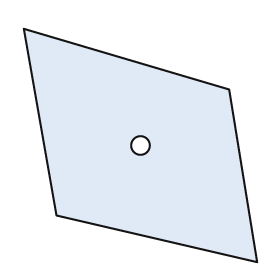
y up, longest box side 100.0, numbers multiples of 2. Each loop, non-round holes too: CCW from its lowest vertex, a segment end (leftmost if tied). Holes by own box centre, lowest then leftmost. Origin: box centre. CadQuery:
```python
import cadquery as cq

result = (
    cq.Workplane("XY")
    .moveTo(50.0, -50.0)
    .lineTo(38.0, 24.0)
    .lineTo(-50.0, 50.0)
    .lineTo(-36.0, -30.0)
    .close()
    .moveTo(0.0, 0.0)
    .circle(4.0)
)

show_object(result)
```